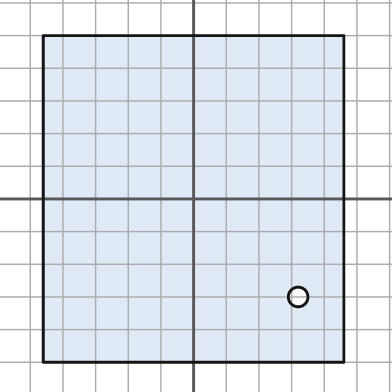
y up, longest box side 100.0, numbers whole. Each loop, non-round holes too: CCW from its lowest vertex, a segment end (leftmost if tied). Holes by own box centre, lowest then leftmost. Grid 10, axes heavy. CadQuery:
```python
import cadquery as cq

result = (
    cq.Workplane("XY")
    .moveTo(-46.0, -50.0)
    .lineTo(46.0, -50.0)
    .lineTo(46.0, 50.0)
    .lineTo(-46.0, 50.0)
    .close()
    .moveTo(32.0, -30.0)
    .circle(3.0)
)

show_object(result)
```